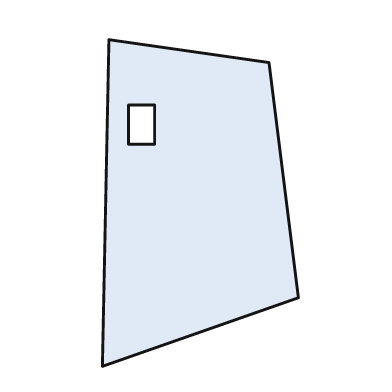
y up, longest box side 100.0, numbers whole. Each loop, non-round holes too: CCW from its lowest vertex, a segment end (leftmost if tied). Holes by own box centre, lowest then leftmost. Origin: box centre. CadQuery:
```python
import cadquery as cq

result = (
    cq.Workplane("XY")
    .moveTo(-30.0, -50.0)
    .lineTo(30.0, -29.0)
    .lineTo(21.0, 43.0)
    .lineTo(-28.0, 50.0)
    .close()
    .moveTo(-22.0, 18.0)
    .lineTo(-14.0, 18.0)
    .lineTo(-14.0, 30.0)
    .lineTo(-22.0, 30.0)
    .close()
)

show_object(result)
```